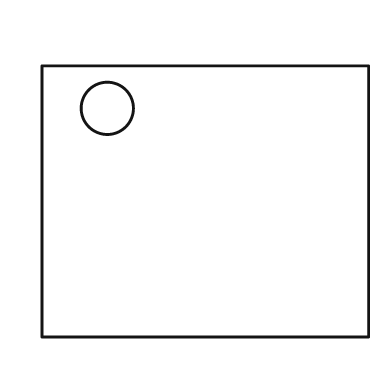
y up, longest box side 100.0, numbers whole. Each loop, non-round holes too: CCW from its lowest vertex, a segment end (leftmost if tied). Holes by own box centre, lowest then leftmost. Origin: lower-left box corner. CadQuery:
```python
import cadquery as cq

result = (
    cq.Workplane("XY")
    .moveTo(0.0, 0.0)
    .lineTo(100.0, 0.0)
    .lineTo(100.0, 83.0)
    .lineTo(0.0, 83.0)
    .close()
    .moveTo(20.0, 70.0)
    .circle(8.0)
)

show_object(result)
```